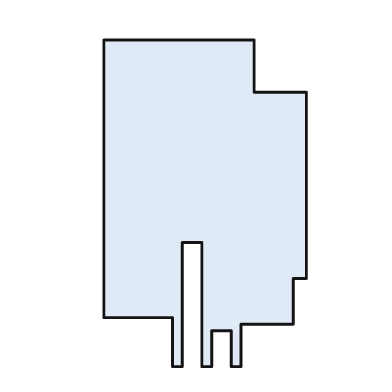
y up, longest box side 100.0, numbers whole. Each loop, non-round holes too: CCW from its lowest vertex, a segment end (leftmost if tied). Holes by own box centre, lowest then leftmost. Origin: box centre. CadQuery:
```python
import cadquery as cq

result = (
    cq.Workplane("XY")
    .moveTo(-10.0, -50.0)
    .lineTo(-7.0, -50.0)
    .lineTo(-7.0, -12.0)
    .lineTo(-1.0, -12.0)
    .lineTo(-1.0, -50.0)
    .lineTo(2.0, -50.0)
    .lineTo(2.0, -39.0)
    .lineTo(8.0, -39.0)
    .lineTo(8.0, -50.0)
    .lineTo(11.0, -50.0)
    .lineTo(11.0, -37.0)
    .lineTo(27.0, -37.0)
    .lineTo(27.0, -23.0)
    .lineTo(31.0, -23.0)
    .lineTo(31.0, 34.0)
    .lineTo(15.0, 34.0)
    .lineTo(15.0, 50.0)
    .lineTo(-31.0, 50.0)
    .lineTo(-31.0, -35.0)
    .lineTo(-10.0, -35.0)
    .close()
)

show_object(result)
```